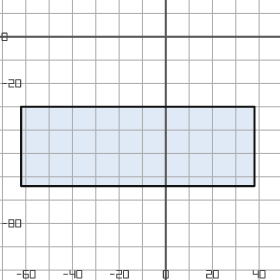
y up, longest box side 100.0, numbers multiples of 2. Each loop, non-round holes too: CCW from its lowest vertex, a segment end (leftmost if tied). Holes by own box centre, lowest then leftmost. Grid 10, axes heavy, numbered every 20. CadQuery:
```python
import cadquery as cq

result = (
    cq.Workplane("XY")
    .moveTo(-62.0, -64.0)
    .lineTo(38.0, -64.0)
    .lineTo(38.0, -30.0)
    .lineTo(-62.0, -30.0)
    .close()
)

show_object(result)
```